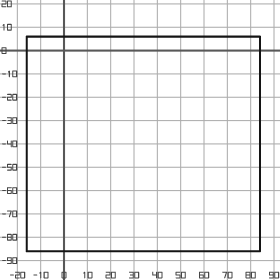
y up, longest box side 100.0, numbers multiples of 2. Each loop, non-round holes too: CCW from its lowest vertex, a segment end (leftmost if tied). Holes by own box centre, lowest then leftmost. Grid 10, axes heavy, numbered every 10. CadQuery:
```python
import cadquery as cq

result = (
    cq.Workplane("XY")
    .moveTo(-16.0, -86.0)
    .lineTo(84.0, -86.0)
    .lineTo(84.0, 6.0)
    .lineTo(-16.0, 6.0)
    .close()
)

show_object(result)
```